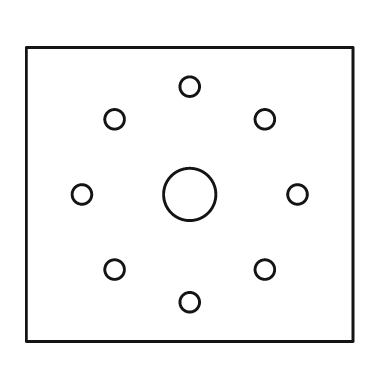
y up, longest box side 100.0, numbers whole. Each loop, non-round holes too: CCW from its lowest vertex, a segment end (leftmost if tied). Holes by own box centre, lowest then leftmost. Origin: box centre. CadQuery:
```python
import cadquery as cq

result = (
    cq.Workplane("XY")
    .moveTo(-50.0, -45.0)
    .lineTo(50.0, -45.0)
    .lineTo(50.0, 45.0)
    .lineTo(-50.0, 45.0)
    .close()
    .moveTo(0.0, -33.0)
    .circle(3.0)
    .moveTo(-23.0, -23.0)
    .circle(3.0)
    .moveTo(23.0, -23.0)
    .circle(3.0)
    .moveTo(-33.0, 0.0)
    .circle(3.0)
    .moveTo(0.0, 0.0)
    .circle(8.0)
    .moveTo(33.0, 0.0)
    .circle(3.0)
    .moveTo(-23.0, 23.0)
    .circle(3.0)
    .moveTo(23.0, 23.0)
    .circle(3.0)
    .moveTo(0.0, 33.0)
    .circle(3.0)
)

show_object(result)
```